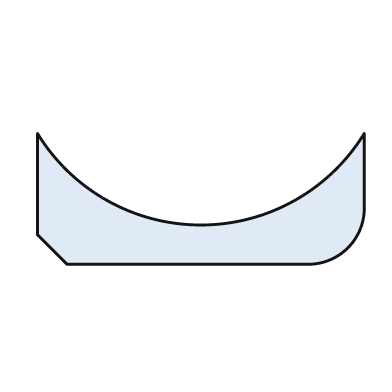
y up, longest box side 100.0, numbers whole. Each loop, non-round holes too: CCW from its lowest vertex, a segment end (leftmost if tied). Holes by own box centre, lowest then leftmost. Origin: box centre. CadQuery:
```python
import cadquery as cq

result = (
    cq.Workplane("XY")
    .moveTo(-41.0, -20.0)
    .lineTo(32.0, -20.0)
    .threePointArc((45.0, -15.0), (50.0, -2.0))
    .lineTo(50.0, 20.0)
    .threePointArc((0.0, -8.0), (-50.0, 20.0))
    .lineTo(-50.0, -11.0)
    .close()
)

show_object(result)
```